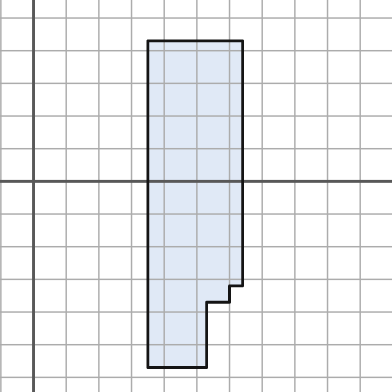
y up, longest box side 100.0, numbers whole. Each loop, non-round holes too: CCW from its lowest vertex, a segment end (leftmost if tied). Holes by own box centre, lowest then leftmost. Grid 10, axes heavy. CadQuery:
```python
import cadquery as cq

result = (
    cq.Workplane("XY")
    .moveTo(35.0, -57.0)
    .lineTo(53.0, -57.0)
    .lineTo(53.0, -37.0)
    .lineTo(60.0, -37.0)
    .lineTo(60.0, -32.0)
    .lineTo(64.0, -32.0)
    .lineTo(64.0, 43.0)
    .lineTo(35.0, 43.0)
    .close()
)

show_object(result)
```